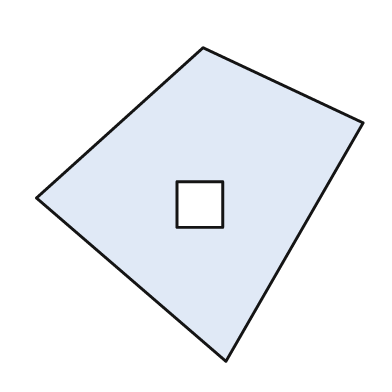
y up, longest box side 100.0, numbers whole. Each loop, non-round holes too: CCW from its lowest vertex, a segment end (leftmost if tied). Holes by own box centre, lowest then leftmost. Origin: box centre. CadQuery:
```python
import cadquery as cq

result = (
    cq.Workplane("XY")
    .moveTo(8.0, -48.0)
    .lineTo(50.0, 25.0)
    .lineTo(1.0, 48.0)
    .lineTo(-50.0, 2.0)
    .close()
    .moveTo(-7.0, -7.0)
    .lineTo(7.0, -7.0)
    .lineTo(7.0, 7.0)
    .lineTo(-7.0, 7.0)
    .close()
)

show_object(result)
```